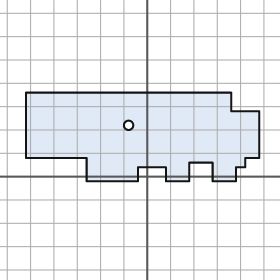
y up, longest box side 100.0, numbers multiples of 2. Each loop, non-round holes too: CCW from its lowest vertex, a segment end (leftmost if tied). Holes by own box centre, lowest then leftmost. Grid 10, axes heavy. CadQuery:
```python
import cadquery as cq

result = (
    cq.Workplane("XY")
    .moveTo(-26.0, -2.0)
    .lineTo(-4.0, -2.0)
    .lineTo(-4.0, 4.0)
    .lineTo(8.0, 4.0)
    .lineTo(8.0, -2.0)
    .lineTo(18.0, -2.0)
    .lineTo(18.0, 6.0)
    .lineTo(28.0, 6.0)
    .lineTo(28.0, -2.0)
    .lineTo(38.0, -2.0)
    .lineTo(38.0, 4.0)
    .lineTo(42.0, 4.0)
    .lineTo(42.0, 8.0)
    .lineTo(48.0, 8.0)
    .lineTo(48.0, 28.0)
    .lineTo(36.0, 28.0)
    .lineTo(36.0, 36.0)
    .lineTo(-52.0, 36.0)
    .lineTo(-52.0, 8.0)
    .lineTo(-26.0, 8.0)
    .close()
    .moveTo(-8.0, 22.0)
    .circle(2.0)
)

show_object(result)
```